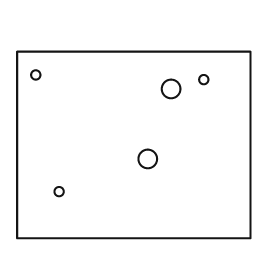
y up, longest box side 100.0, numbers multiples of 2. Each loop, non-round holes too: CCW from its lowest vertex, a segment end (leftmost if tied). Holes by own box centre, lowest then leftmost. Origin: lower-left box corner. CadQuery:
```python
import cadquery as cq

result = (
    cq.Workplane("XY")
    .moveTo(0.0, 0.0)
    .lineTo(100.0, 0.0)
    .lineTo(100.0, 80.0)
    .lineTo(0.0, 80.0)
    .close()
    .moveTo(18.0, 20.0)
    .circle(2.0)
    .moveTo(56.0, 34.0)
    .circle(4.0)
    .moveTo(66.0, 64.0)
    .circle(4.0)
    .moveTo(80.0, 68.0)
    .circle(2.0)
    .moveTo(8.0, 70.0)
    .circle(2.0)
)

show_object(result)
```